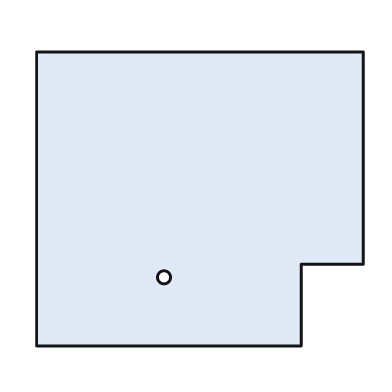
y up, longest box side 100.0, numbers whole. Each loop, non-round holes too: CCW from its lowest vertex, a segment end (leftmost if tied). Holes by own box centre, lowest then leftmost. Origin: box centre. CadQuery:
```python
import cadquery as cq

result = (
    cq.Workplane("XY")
    .moveTo(-50.0, -45.0)
    .lineTo(31.0, -45.0)
    .lineTo(31.0, -20.0)
    .lineTo(50.0, -20.0)
    .lineTo(50.0, 45.0)
    .lineTo(-50.0, 45.0)
    .close()
    .moveTo(-11.0, -24.0)
    .circle(2.0)
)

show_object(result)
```